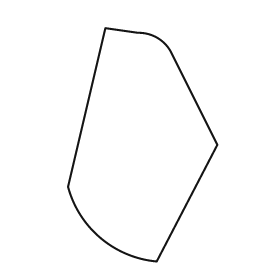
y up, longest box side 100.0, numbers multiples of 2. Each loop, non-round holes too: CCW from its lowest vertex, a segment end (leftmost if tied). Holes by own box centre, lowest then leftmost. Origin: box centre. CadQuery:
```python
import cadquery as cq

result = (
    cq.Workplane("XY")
    .moveTo(6.0, -50.0)
    .lineTo(32.0, 0.0)
    .lineTo(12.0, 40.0)
    .threePointArc((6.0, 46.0), (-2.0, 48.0))
    .lineTo(-16.0, 50.0)
    .lineTo(-32.0, -18.0)
    .threePointArc((-18.0, -40.0), (6.0, -50.0))
    .close()
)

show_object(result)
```